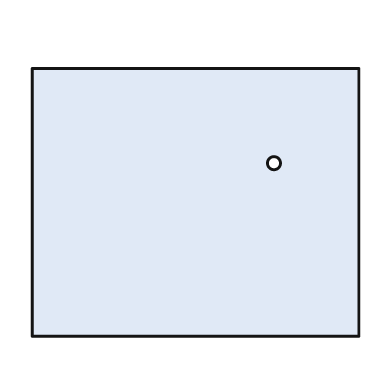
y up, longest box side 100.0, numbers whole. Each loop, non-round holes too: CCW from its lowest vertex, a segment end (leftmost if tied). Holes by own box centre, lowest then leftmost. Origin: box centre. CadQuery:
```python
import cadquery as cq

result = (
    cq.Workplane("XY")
    .moveTo(-50.0, -41.0)
    .lineTo(50.0, -41.0)
    .lineTo(50.0, 41.0)
    .lineTo(-50.0, 41.0)
    .close()
    .moveTo(24.0, 12.0)
    .circle(2.0)
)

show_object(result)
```